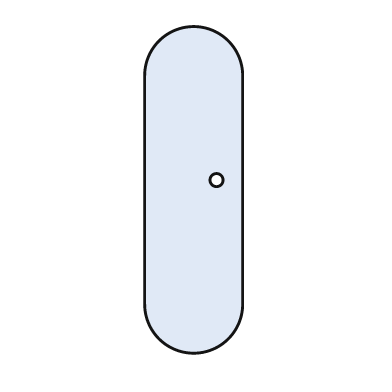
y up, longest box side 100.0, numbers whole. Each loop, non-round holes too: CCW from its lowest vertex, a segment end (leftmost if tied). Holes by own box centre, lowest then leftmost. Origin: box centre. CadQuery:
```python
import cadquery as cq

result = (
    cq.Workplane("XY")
    .moveTo(-15.0, -35.0)
    .threePointArc((0.0, -50.0), (15.0, -35.0))
    .lineTo(15.0, 35.0)
    .threePointArc((0.0, 50.0), (-15.0, 35.0))
    .close()
    .moveTo(7.0, 3.0)
    .circle(2.0)
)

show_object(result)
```